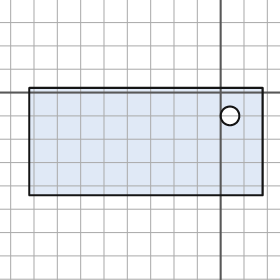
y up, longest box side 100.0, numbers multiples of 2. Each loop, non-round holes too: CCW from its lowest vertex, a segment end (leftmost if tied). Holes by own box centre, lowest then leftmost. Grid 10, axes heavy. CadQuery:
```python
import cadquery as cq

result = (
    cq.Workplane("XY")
    .moveTo(-82.0, -44.0)
    .lineTo(18.0, -44.0)
    .lineTo(18.0, 2.0)
    .lineTo(-82.0, 2.0)
    .close()
    .moveTo(4.0, -10.0)
    .circle(4.0)
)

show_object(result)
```